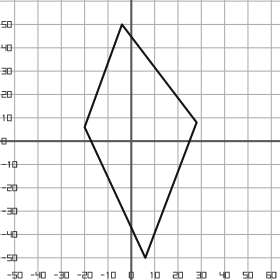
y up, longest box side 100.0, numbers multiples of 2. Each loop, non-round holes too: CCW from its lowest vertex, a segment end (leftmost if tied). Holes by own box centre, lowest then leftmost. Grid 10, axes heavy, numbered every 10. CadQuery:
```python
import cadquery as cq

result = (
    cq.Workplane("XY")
    .moveTo(6.0, -50.0)
    .lineTo(28.0, 8.0)
    .lineTo(-4.0, 50.0)
    .lineTo(-20.0, 6.0)
    .close()
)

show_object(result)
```